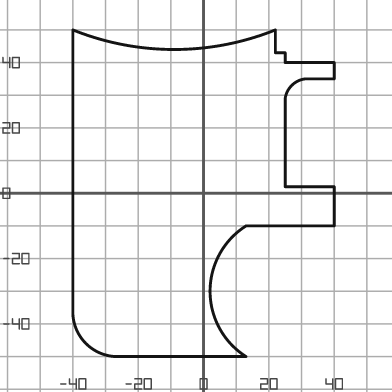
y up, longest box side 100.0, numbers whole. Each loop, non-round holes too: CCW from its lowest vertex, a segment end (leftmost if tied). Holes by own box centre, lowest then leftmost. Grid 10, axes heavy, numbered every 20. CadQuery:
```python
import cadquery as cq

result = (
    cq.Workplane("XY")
    .moveTo(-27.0, -50.0)
    .lineTo(13.0, -50.0)
    .threePointArc((2.0, -30.0), (13.0, -10.0))
    .lineTo(40.0, -10.0)
    .lineTo(40.0, 2.0)
    .lineTo(25.0, 2.0)
    .lineTo(25.0, 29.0)
    .threePointArc((27.0, 33.0), (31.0, 35.0))
    .lineTo(40.0, 35.0)
    .lineTo(40.0, 40.0)
    .lineTo(25.0, 40.0)
    .lineTo(25.0, 43.0)
    .lineTo(22.0, 43.0)
    .lineTo(22.0, 50.0)
    .threePointArc((-9.0, 44.0), (-40.0, 50.0))
    .lineTo(-40.0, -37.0)
    .threePointArc((-36.0, -46.0), (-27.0, -50.0))
    .close()
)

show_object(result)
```